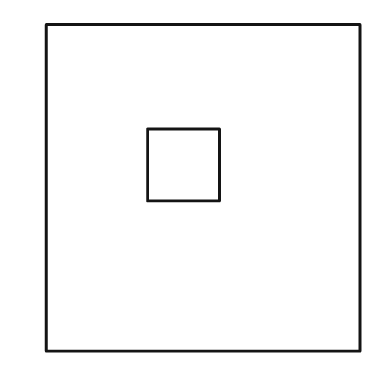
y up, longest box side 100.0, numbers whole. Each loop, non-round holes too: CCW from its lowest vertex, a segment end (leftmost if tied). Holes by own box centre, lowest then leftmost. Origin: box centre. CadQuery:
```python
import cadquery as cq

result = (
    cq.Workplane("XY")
    .moveTo(-48.0, -50.0)
    .lineTo(48.0, -50.0)
    .lineTo(48.0, 50.0)
    .lineTo(-48.0, 50.0)
    .close()
    .moveTo(-17.0, -4.0)
    .lineTo(5.0, -4.0)
    .lineTo(5.0, 18.0)
    .lineTo(-17.0, 18.0)
    .close()
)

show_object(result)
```